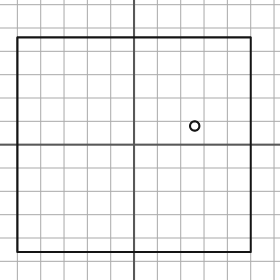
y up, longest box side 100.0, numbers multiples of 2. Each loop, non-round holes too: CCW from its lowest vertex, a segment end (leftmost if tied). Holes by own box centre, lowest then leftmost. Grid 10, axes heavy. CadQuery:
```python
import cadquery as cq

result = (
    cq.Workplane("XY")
    .moveTo(-50.0, -46.0)
    .lineTo(50.0, -46.0)
    .lineTo(50.0, 46.0)
    .lineTo(-50.0, 46.0)
    .close()
    .moveTo(26.0, 8.0)
    .circle(2.0)
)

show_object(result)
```